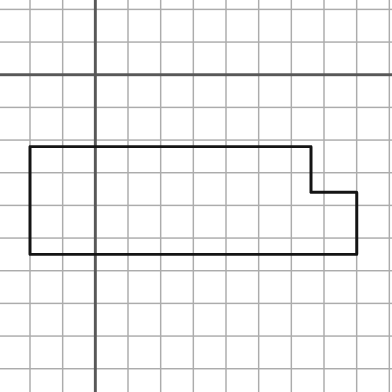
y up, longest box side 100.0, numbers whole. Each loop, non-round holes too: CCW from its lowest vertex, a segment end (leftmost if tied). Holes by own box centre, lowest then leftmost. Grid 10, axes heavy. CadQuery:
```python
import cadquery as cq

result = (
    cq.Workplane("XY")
    .moveTo(-20.0, -55.0)
    .lineTo(80.0, -55.0)
    .lineTo(80.0, -36.0)
    .lineTo(66.0, -36.0)
    .lineTo(66.0, -22.0)
    .lineTo(-20.0, -22.0)
    .close()
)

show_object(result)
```